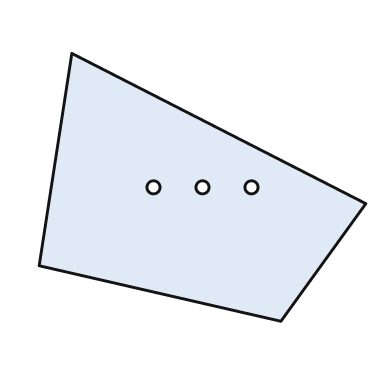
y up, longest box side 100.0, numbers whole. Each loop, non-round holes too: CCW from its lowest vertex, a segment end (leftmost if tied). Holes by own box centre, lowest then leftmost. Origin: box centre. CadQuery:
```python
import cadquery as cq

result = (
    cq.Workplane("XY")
    .moveTo(24.0, -41.0)
    .lineTo(50.0, -5.0)
    .lineTo(-40.0, 41.0)
    .lineTo(-50.0, -24.0)
    .close()
    .moveTo(-15.0, 0.0)
    .circle(2.0)
    .moveTo(0.0, 0.0)
    .circle(2.0)
    .moveTo(15.0, 0.0)
    .circle(2.0)
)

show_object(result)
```